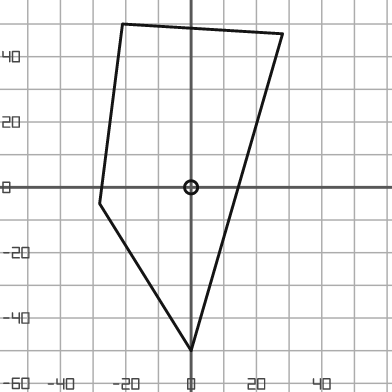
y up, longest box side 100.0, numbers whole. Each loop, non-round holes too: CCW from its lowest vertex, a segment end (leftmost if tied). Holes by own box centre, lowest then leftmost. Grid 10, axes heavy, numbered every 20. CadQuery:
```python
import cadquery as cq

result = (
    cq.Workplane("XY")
    .moveTo(0.0, -50.0)
    .lineTo(28.0, 47.0)
    .lineTo(-21.0, 50.0)
    .lineTo(-28.0, -5.0)
    .close()
    .moveTo(0.0, 0.0)
    .circle(2.0)
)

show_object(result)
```